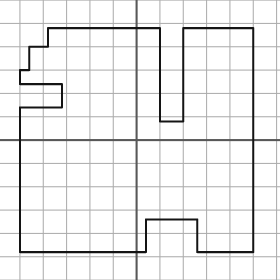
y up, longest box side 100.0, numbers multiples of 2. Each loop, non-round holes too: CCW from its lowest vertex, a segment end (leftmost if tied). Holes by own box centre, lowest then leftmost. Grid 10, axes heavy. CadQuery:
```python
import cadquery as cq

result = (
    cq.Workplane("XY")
    .moveTo(-50.0, -48.0)
    .lineTo(4.0, -48.0)
    .lineTo(4.0, -34.0)
    .lineTo(26.0, -34.0)
    .lineTo(26.0, -48.0)
    .lineTo(50.0, -48.0)
    .lineTo(50.0, 48.0)
    .lineTo(20.0, 48.0)
    .lineTo(20.0, 8.0)
    .lineTo(10.0, 8.0)
    .lineTo(10.0, 48.0)
    .lineTo(-38.0, 48.0)
    .lineTo(-38.0, 40.0)
    .lineTo(-46.0, 40.0)
    .lineTo(-46.0, 30.0)
    .lineTo(-50.0, 30.0)
    .lineTo(-50.0, 24.0)
    .lineTo(-32.0, 24.0)
    .lineTo(-32.0, 14.0)
    .lineTo(-50.0, 14.0)
    .close()
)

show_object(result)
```